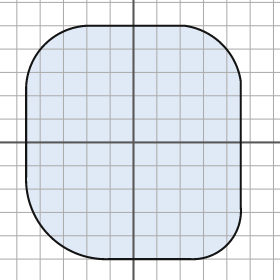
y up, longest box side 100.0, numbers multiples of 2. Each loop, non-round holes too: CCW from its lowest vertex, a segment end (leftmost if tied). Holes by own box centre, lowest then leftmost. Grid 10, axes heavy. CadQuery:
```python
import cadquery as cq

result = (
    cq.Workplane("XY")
    .moveTo(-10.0, -50.0)
    .lineTo(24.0, -50.0)
    .threePointArc((40.0, -44.0), (46.0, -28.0))
    .lineTo(46.0, 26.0)
    .threePointArc((38.0, 42.0), (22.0, 50.0))
    .lineTo(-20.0, 50.0)
    .threePointArc((-38.0, 42.0), (-46.0, 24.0))
    .lineTo(-46.0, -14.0)
    .threePointArc((-36.0, -40.0), (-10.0, -50.0))
    .close()
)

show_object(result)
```